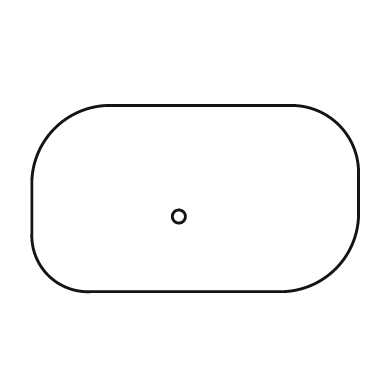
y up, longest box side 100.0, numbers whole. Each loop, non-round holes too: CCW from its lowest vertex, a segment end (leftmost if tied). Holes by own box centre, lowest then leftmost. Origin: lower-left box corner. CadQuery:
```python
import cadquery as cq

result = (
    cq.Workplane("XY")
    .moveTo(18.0, 0.0)
    .lineTo(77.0, 0.0)
    .threePointArc((93.0, 7.0), (100.0, 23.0))
    .lineTo(100.0, 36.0)
    .threePointArc((94.0, 51.0), (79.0, 57.0))
    .lineTo(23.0, 57.0)
    .threePointArc((7.0, 50.0), (0.0, 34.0))
    .lineTo(0.0, 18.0)
    .threePointArc((5.0, 5.0), (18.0, 0.0))
    .close()
    .moveTo(45.0, 23.0)
    .circle(2.0)
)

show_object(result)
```